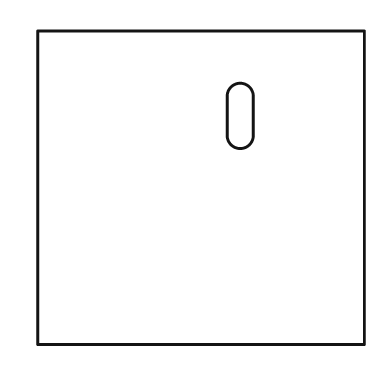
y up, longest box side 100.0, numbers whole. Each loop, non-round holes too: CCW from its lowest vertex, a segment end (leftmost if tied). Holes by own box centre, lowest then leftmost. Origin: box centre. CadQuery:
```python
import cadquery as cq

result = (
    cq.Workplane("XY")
    .moveTo(-50.0, -48.0)
    .lineTo(50.0, -48.0)
    .lineTo(50.0, 48.0)
    .lineTo(-50.0, 48.0)
    .close()
    .moveTo(8.0, 16.0)
    .threePointArc((12.0, 12.0), (16.0, 16.0))
    .lineTo(16.0, 28.0)
    .threePointArc((12.0, 32.0), (8.0, 28.0))
    .close()
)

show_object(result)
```